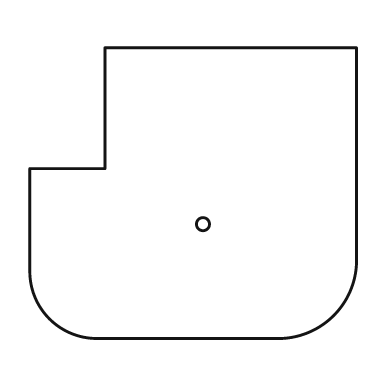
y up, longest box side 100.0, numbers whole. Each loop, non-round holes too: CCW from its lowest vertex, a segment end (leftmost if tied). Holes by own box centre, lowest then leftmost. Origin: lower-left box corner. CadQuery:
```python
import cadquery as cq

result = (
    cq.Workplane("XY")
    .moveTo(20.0, 0.0)
    .lineTo(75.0, 0.0)
    .threePointArc((93.0, 7.0), (100.0, 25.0))
    .lineTo(100.0, 89.0)
    .lineTo(23.0, 89.0)
    .lineTo(23.0, 52.0)
    .lineTo(0.0, 52.0)
    .lineTo(0.0, 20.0)
    .threePointArc((6.0, 6.0), (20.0, 0.0))
    .close()
    .moveTo(53.0, 35.0)
    .circle(2.0)
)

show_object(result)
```